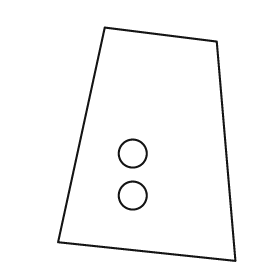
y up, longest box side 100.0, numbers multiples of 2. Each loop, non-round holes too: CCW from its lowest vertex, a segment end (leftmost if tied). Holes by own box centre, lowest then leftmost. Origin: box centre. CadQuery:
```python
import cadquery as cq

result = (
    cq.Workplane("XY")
    .moveTo(38.0, -50.0)
    .lineTo(30.0, 44.0)
    .lineTo(-18.0, 50.0)
    .lineTo(-38.0, -42.0)
    .close()
    .moveTo(-6.0, -22.0)
    .circle(6.0)
    .moveTo(-6.0, -4.0)
    .circle(6.0)
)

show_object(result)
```